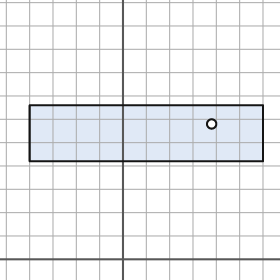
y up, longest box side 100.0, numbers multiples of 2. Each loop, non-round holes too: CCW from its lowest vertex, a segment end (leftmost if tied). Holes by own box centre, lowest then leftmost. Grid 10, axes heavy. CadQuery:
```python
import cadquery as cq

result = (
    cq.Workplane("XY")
    .moveTo(-40.0, 42.0)
    .lineTo(60.0, 42.0)
    .lineTo(60.0, 66.0)
    .lineTo(-40.0, 66.0)
    .close()
    .moveTo(38.0, 58.0)
    .circle(2.0)
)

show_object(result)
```